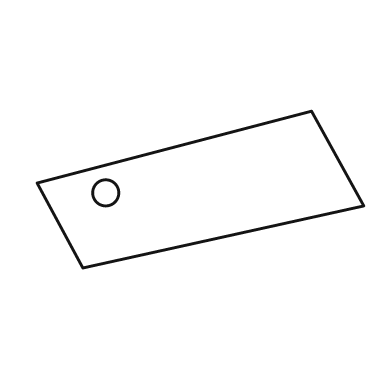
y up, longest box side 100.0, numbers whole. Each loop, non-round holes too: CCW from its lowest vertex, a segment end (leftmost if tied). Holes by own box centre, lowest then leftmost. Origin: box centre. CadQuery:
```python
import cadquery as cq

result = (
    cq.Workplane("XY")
    .moveTo(-36.0, -24.0)
    .lineTo(50.0, -5.0)
    .lineTo(34.0, 24.0)
    .lineTo(-50.0, 2.0)
    .close()
    .moveTo(-29.0, -1.0)
    .circle(4.0)
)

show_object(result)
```